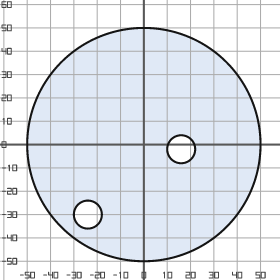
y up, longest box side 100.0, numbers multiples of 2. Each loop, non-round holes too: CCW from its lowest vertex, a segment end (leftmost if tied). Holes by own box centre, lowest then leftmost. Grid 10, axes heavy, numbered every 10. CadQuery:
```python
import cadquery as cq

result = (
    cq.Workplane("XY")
    .moveTo(0.0, 0.0)
    .circle(50.0)
    .moveTo(-24.0, -30.0)
    .circle(6.0)
    .moveTo(16.0, -2.0)
    .circle(6.0)
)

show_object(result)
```